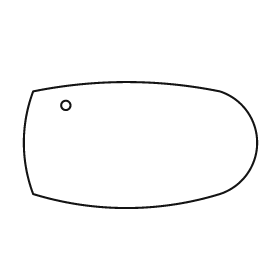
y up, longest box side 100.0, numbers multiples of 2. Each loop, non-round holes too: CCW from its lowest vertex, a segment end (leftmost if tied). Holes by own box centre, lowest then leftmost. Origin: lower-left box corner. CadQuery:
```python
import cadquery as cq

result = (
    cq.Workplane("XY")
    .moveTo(4.0, 6.0)
    .threePointArc((44.0, 0.0), (84.0, 6.0))
    .threePointArc((100.0, 28.0), (84.0, 50.0))
    .threePointArc((44.0, 54.0), (4.0, 50.0))
    .threePointArc((0.0, 28.0), (4.0, 6.0))
    .close()
    .moveTo(18.0, 44.0)
    .circle(2.0)
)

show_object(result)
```